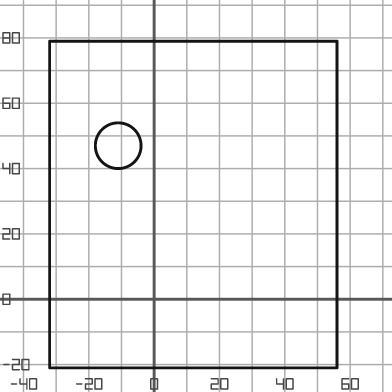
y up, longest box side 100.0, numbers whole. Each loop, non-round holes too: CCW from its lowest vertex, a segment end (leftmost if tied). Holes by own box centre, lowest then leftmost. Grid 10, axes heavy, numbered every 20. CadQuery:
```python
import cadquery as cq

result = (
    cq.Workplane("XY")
    .moveTo(-32.0, -21.0)
    .lineTo(56.0, -21.0)
    .lineTo(56.0, 79.0)
    .lineTo(-32.0, 79.0)
    .close()
    .moveTo(-11.0, 47.0)
    .circle(7.0)
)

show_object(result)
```